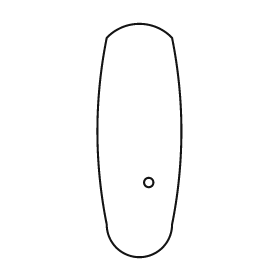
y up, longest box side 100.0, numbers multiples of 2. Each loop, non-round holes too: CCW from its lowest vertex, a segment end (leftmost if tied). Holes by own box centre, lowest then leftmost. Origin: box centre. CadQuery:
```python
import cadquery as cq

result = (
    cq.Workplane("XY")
    .moveTo(-14.0, -36.0)
    .threePointArc((0.0, -50.0), (14.0, -36.0))
    .threePointArc((18.0, 4.0), (14.0, 44.0))
    .threePointArc((0.0, 50.0), (-14.0, 44.0))
    .threePointArc((-18.0, 4.0), (-14.0, -36.0))
    .close()
    .moveTo(4.0, -18.0)
    .circle(2.0)
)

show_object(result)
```